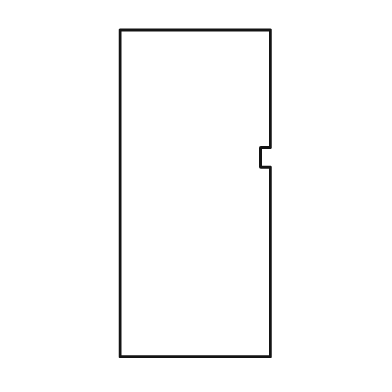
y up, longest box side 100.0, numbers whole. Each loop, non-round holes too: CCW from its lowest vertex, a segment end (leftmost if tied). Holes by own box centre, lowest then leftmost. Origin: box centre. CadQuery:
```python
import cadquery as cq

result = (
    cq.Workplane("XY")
    .moveTo(-23.0, -50.0)
    .lineTo(23.0, -50.0)
    .lineTo(23.0, 8.0)
    .lineTo(20.0, 8.0)
    .lineTo(20.0, 14.0)
    .lineTo(23.0, 14.0)
    .lineTo(23.0, 50.0)
    .lineTo(-23.0, 50.0)
    .close()
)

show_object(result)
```